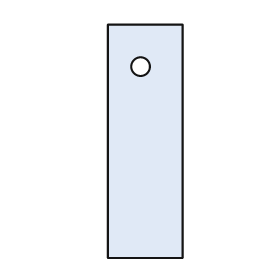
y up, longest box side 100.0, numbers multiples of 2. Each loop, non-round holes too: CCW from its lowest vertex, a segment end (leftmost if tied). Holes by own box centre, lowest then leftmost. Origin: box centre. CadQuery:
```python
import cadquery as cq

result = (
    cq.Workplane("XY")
    .moveTo(-16.0, -50.0)
    .lineTo(16.0, -50.0)
    .lineTo(16.0, 50.0)
    .lineTo(-16.0, 50.0)
    .close()
    .moveTo(-2.0, 32.0)
    .circle(4.0)
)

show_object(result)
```